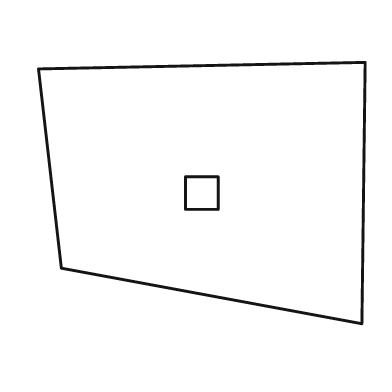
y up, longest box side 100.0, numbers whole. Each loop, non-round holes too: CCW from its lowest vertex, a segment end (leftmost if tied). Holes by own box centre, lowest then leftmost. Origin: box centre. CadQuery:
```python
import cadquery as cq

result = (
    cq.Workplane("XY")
    .moveTo(49.0, -40.0)
    .lineTo(50.0, 40.0)
    .lineTo(-50.0, 38.0)
    .lineTo(-43.0, -23.0)
    .close()
    .moveTo(-5.0, -5.0)
    .lineTo(5.0, -5.0)
    .lineTo(5.0, 5.0)
    .lineTo(-5.0, 5.0)
    .close()
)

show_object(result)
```